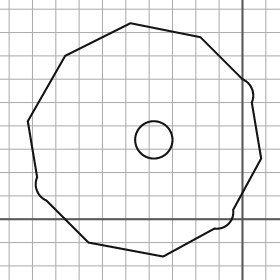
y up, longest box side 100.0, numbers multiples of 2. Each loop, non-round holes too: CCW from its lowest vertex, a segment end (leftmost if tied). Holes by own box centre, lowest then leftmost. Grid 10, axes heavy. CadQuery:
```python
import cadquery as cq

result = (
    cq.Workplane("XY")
    .moveTo(-34.0, -16.0)
    .lineTo(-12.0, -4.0)
    .threePointArc((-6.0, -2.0), (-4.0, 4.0))
    .lineTo(8.0, 26.0)
    .lineTo(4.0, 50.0)
    .threePointArc((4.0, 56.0), (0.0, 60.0))
    .lineTo(-18.0, 78.0)
    .lineTo(-48.0, 84.0)
    .lineTo(-76.0, 70.0)
    .lineTo(-92.0, 42.0)
    .lineTo(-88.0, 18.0)
    .threePointArc((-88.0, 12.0), (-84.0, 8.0))
    .lineTo(-66.0, -10.0)
    .close()
    .moveTo(-38.0, 34.0)
    .circle(8.0)
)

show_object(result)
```